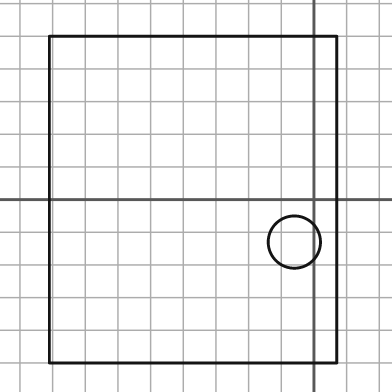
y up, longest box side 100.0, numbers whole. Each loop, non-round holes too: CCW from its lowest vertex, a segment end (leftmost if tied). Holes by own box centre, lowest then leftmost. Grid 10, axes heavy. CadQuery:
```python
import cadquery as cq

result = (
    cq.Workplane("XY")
    .moveTo(-81.0, -50.0)
    .lineTo(7.0, -50.0)
    .lineTo(7.0, 50.0)
    .lineTo(-81.0, 50.0)
    .close()
    .moveTo(-6.0, -13.0)
    .circle(8.0)
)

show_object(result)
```